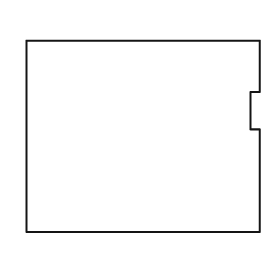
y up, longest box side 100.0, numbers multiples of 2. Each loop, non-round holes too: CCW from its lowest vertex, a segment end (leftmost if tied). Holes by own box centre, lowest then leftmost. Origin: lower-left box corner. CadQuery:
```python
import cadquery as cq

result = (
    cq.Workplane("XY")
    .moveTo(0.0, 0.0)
    .lineTo(100.0, 0.0)
    .lineTo(100.0, 44.0)
    .lineTo(96.0, 44.0)
    .lineTo(96.0, 60.0)
    .lineTo(100.0, 60.0)
    .lineTo(100.0, 82.0)
    .lineTo(0.0, 82.0)
    .close()
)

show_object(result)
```